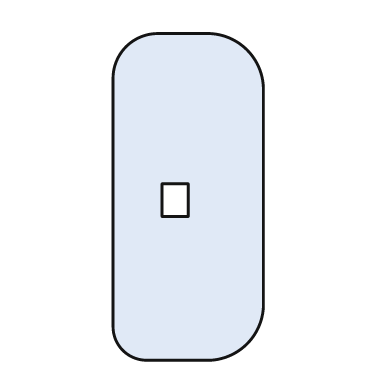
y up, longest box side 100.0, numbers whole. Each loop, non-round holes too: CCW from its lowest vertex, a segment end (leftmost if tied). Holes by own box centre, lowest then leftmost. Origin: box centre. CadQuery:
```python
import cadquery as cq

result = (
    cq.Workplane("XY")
    .moveTo(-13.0, -50.0)
    .lineTo(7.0, -50.0)
    .threePointArc((18.0, -45.0), (23.0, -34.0))
    .lineTo(23.0, 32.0)
    .threePointArc((18.0, 45.0), (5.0, 50.0))
    .lineTo(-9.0, 50.0)
    .threePointArc((-19.0, 46.0), (-23.0, 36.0))
    .lineTo(-23.0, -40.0)
    .threePointArc((-20.0, -47.0), (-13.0, -50.0))
    .close()
    .moveTo(-8.0, -6.0)
    .lineTo(0.0, -6.0)
    .lineTo(0.0, 4.0)
    .lineTo(-8.0, 4.0)
    .close()
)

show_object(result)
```